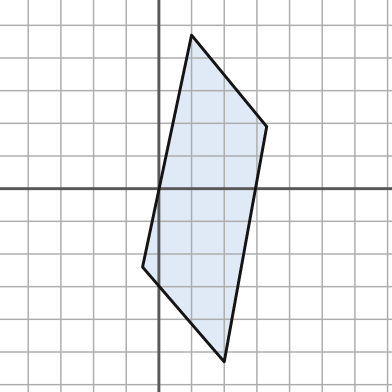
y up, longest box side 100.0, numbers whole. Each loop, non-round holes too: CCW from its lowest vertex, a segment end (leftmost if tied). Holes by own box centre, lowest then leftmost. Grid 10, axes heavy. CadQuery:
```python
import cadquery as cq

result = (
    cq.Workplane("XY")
    .moveTo(20.0, -53.0)
    .lineTo(33.0, 19.0)
    .lineTo(10.0, 47.0)
    .lineTo(-5.0, -24.0)
    .close()
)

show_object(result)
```